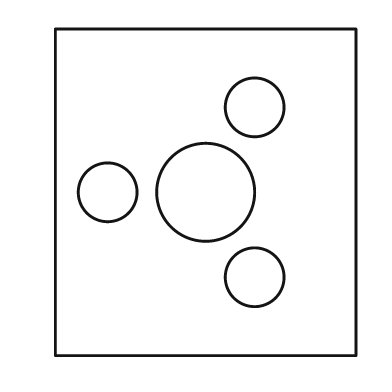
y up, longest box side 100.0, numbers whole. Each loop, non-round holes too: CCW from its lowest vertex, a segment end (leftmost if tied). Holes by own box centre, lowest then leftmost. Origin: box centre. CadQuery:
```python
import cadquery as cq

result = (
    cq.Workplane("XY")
    .moveTo(-46.0, -50.0)
    .lineTo(46.0, -50.0)
    .lineTo(46.0, 50.0)
    .lineTo(-46.0, 50.0)
    .close()
    .moveTo(15.0, -26.0)
    .circle(9.0)
    .moveTo(-30.0, 0.0)
    .circle(9.0)
    .moveTo(0.0, 0.0)
    .circle(15.0)
    .moveTo(15.0, 26.0)
    .circle(9.0)
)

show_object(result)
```